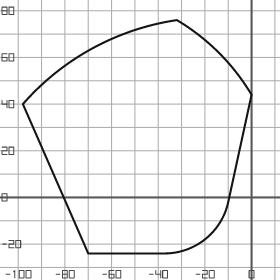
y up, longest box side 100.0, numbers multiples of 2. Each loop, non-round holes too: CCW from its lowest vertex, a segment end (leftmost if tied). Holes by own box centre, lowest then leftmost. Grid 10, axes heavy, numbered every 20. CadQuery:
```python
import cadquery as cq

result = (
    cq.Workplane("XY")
    .moveTo(-70.0, -24.0)
    .lineTo(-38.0, -24.0)
    .threePointArc((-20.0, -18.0), (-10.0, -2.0))
    .lineTo(0.0, 44.0)
    .threePointArc((-14.0, 62.0), (-32.0, 76.0))
    .threePointArc((-68.0, 64.0), (-98.0, 40.0))
    .close()
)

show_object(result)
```